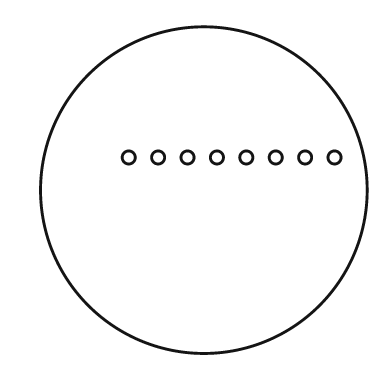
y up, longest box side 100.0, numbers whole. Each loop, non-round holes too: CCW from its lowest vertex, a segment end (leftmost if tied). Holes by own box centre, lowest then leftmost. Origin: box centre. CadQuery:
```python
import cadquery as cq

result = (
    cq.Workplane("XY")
    .moveTo(0.0, 0.0)
    .circle(50.0)
    .moveTo(-23.0, 10.0)
    .circle(2.0)
    .moveTo(-14.0, 10.0)
    .circle(2.0)
    .moveTo(-5.0, 10.0)
    .circle(2.0)
    .moveTo(4.0, 10.0)
    .circle(2.0)
    .moveTo(13.0, 10.0)
    .circle(2.0)
    .moveTo(22.0, 10.0)
    .circle(2.0)
    .moveTo(31.0, 10.0)
    .circle(2.0)
    .moveTo(40.0, 10.0)
    .circle(2.0)
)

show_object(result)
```